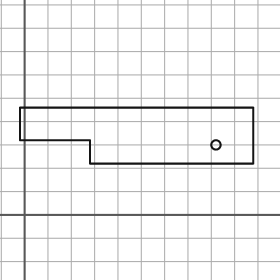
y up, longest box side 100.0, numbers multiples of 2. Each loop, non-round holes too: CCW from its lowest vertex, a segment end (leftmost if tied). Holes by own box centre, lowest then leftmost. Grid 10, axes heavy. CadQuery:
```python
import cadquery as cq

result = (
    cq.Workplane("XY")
    .moveTo(28.0, 22.0)
    .lineTo(98.0, 22.0)
    .lineTo(98.0, 46.0)
    .lineTo(-2.0, 46.0)
    .lineTo(-2.0, 32.0)
    .lineTo(28.0, 32.0)
    .close()
    .moveTo(82.0, 30.0)
    .circle(2.0)
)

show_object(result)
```